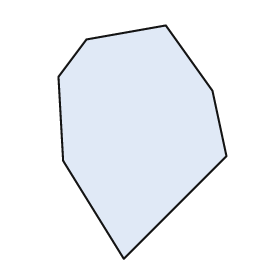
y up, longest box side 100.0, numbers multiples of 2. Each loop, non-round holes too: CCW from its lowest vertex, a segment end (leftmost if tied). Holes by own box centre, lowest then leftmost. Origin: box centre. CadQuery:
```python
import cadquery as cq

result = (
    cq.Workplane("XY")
    .moveTo(-8.0, -50.0)
    .lineTo(36.0, -6.0)
    .lineTo(30.0, 22.0)
    .lineTo(10.0, 50.0)
    .lineTo(-24.0, 44.0)
    .lineTo(-36.0, 28.0)
    .lineTo(-34.0, -8.0)
    .close()
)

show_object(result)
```